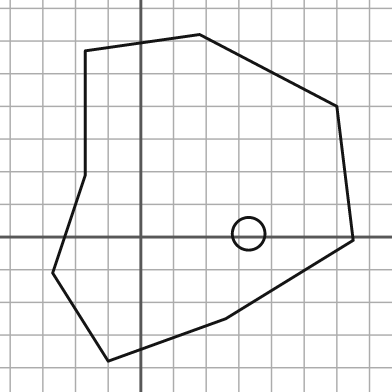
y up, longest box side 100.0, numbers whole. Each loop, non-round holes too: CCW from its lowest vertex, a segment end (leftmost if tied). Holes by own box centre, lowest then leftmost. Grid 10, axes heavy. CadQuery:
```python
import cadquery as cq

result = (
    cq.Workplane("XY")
    .moveTo(-10.0, -38.0)
    .lineTo(26.0, -25.0)
    .lineTo(65.0, -1.0)
    .lineTo(60.0, 40.0)
    .lineTo(18.0, 62.0)
    .lineTo(-17.0, 57.0)
    .lineTo(-17.0, 19.0)
    .lineTo(-27.0, -11.0)
    .close()
    .moveTo(33.0, 1.0)
    .circle(5.0)
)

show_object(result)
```